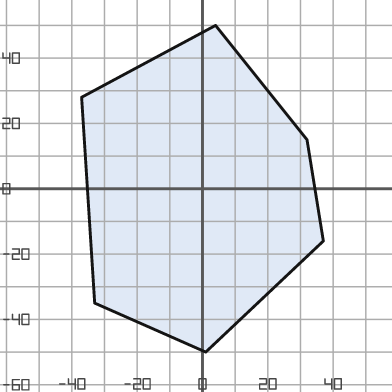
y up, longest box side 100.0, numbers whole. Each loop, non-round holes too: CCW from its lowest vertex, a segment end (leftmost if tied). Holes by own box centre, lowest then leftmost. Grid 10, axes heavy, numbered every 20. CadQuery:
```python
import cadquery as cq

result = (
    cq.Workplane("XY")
    .moveTo(1.0, -50.0)
    .lineTo(37.0, -16.0)
    .lineTo(32.0, 15.0)
    .lineTo(4.0, 50.0)
    .lineTo(-37.0, 28.0)
    .lineTo(-33.0, -35.0)
    .close()
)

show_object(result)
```